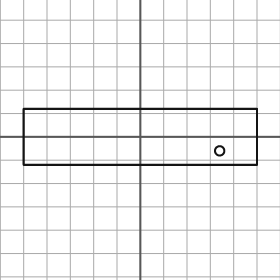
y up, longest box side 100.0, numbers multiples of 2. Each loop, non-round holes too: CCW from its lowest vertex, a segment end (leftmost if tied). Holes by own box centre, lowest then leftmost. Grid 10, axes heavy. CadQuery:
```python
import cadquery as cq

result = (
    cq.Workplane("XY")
    .moveTo(-50.0, -12.0)
    .lineTo(50.0, -12.0)
    .lineTo(50.0, 12.0)
    .lineTo(-50.0, 12.0)
    .close()
    .moveTo(34.0, -6.0)
    .circle(2.0)
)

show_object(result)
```